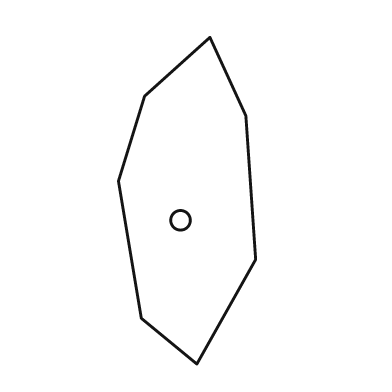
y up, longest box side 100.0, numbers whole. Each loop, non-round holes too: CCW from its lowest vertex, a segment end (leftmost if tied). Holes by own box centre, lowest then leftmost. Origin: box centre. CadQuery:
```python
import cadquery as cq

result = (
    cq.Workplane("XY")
    .moveTo(3.0, -50.0)
    .lineTo(21.0, -18.0)
    .lineTo(18.0, 26.0)
    .lineTo(7.0, 50.0)
    .lineTo(-13.0, 32.0)
    .lineTo(-21.0, 6.0)
    .lineTo(-14.0, -36.0)
    .close()
    .moveTo(-2.0, -6.0)
    .circle(3.0)
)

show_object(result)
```